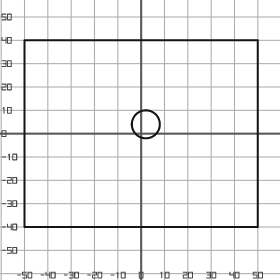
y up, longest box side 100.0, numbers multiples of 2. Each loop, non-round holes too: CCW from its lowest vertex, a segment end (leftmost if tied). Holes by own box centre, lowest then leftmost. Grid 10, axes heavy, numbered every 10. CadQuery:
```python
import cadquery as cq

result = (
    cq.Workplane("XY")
    .moveTo(-50.0, -40.0)
    .lineTo(50.0, -40.0)
    .lineTo(50.0, 40.0)
    .lineTo(-50.0, 40.0)
    .close()
    .moveTo(2.0, 4.0)
    .circle(6.0)
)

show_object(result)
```